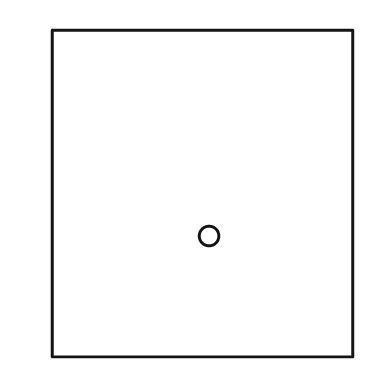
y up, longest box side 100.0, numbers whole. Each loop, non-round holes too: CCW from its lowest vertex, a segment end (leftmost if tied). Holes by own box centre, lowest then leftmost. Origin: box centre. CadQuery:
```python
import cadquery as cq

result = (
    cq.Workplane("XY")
    .moveTo(-46.0, -50.0)
    .lineTo(46.0, -50.0)
    .lineTo(46.0, 50.0)
    .lineTo(-46.0, 50.0)
    .close()
    .moveTo(2.0, -13.0)
    .circle(3.0)
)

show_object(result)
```